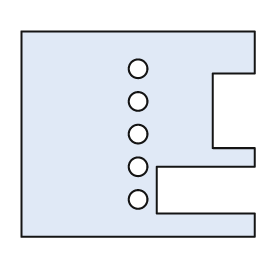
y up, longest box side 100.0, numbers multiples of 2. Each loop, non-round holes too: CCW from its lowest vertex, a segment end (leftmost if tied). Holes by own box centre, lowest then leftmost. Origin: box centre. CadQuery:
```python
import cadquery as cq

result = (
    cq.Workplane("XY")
    .moveTo(-50.0, -44.0)
    .lineTo(50.0, -44.0)
    .lineTo(50.0, -34.0)
    .lineTo(8.0, -34.0)
    .lineTo(8.0, -14.0)
    .lineTo(50.0, -14.0)
    .lineTo(50.0, -6.0)
    .lineTo(32.0, -6.0)
    .lineTo(32.0, 26.0)
    .lineTo(50.0, 26.0)
    .lineTo(50.0, 44.0)
    .lineTo(-50.0, 44.0)
    .close()
    .moveTo(0.0, -28.0)
    .circle(4.0)
    .moveTo(0.0, -14.0)
    .circle(4.0)
    .moveTo(0.0, 0.0)
    .circle(4.0)
    .moveTo(0.0, 14.0)
    .circle(4.0)
    .moveTo(0.0, 28.0)
    .circle(4.0)
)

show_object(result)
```